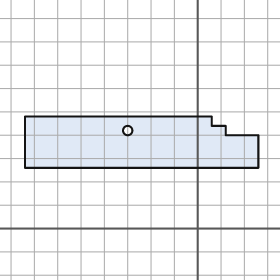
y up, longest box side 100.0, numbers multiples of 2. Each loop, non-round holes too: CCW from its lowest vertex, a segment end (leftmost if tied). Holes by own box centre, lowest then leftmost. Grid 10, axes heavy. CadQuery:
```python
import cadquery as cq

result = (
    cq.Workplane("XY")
    .moveTo(-74.0, 26.0)
    .lineTo(26.0, 26.0)
    .lineTo(26.0, 40.0)
    .lineTo(12.0, 40.0)
    .lineTo(12.0, 44.0)
    .lineTo(6.0, 44.0)
    .lineTo(6.0, 48.0)
    .lineTo(-74.0, 48.0)
    .close()
    .moveTo(-30.0, 42.0)
    .circle(2.0)
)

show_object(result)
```